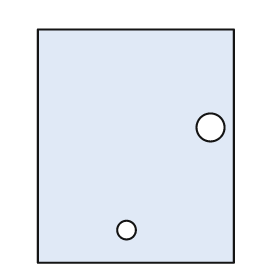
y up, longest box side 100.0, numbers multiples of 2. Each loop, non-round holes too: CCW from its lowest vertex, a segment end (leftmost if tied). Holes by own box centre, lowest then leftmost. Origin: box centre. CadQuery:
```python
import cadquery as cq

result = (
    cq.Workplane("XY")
    .moveTo(-42.0, -50.0)
    .lineTo(42.0, -50.0)
    .lineTo(42.0, 50.0)
    .lineTo(-42.0, 50.0)
    .close()
    .moveTo(-4.0, -36.0)
    .circle(4.0)
    .moveTo(32.0, 8.0)
    .circle(6.0)
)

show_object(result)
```